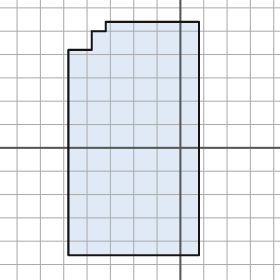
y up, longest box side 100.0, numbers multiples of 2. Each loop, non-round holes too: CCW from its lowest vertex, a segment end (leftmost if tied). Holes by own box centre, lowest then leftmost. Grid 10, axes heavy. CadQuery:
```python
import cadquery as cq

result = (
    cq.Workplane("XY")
    .moveTo(-48.0, -46.0)
    .lineTo(8.0, -46.0)
    .lineTo(8.0, 54.0)
    .lineTo(-32.0, 54.0)
    .lineTo(-32.0, 50.0)
    .lineTo(-38.0, 50.0)
    .lineTo(-38.0, 42.0)
    .lineTo(-48.0, 42.0)
    .close()
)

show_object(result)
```